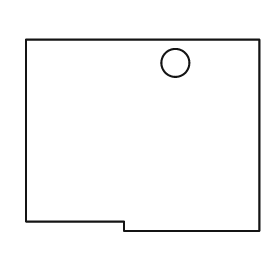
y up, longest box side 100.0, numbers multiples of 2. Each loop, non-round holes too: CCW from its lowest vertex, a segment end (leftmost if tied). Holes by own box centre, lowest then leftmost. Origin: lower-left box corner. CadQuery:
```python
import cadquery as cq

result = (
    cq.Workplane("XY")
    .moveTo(42.0, 0.0)
    .lineTo(100.0, 0.0)
    .lineTo(100.0, 82.0)
    .lineTo(0.0, 82.0)
    .lineTo(0.0, 4.0)
    .lineTo(42.0, 4.0)
    .close()
    .moveTo(64.0, 72.0)
    .circle(6.0)
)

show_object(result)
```